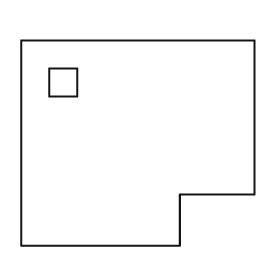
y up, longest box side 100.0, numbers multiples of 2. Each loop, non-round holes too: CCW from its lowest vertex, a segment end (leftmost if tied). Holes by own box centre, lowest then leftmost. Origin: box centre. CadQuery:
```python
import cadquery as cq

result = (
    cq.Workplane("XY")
    .moveTo(-50.0, -44.0)
    .lineTo(18.0, -44.0)
    .lineTo(18.0, -22.0)
    .lineTo(50.0, -22.0)
    .lineTo(50.0, 44.0)
    .lineTo(-50.0, 44.0)
    .close()
    .moveTo(-38.0, 20.0)
    .lineTo(-26.0, 20.0)
    .lineTo(-26.0, 32.0)
    .lineTo(-38.0, 32.0)
    .close()
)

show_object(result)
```